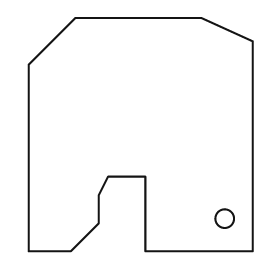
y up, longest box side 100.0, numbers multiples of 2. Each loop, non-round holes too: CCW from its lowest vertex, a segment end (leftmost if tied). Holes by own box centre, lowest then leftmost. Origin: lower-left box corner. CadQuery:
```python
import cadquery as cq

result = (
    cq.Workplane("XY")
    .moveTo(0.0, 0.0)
    .lineTo(18.0, 0.0)
    .lineTo(30.0, 12.0)
    .lineTo(30.0, 24.0)
    .lineTo(34.0, 32.0)
    .lineTo(50.0, 32.0)
    .lineTo(50.0, 0.0)
    .lineTo(96.0, 0.0)
    .lineTo(96.0, 90.0)
    .lineTo(74.0, 100.0)
    .lineTo(20.0, 100.0)
    .lineTo(0.0, 80.0)
    .close()
    .moveTo(84.0, 14.0)
    .circle(4.0)
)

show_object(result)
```